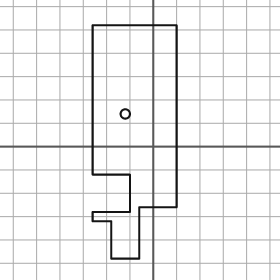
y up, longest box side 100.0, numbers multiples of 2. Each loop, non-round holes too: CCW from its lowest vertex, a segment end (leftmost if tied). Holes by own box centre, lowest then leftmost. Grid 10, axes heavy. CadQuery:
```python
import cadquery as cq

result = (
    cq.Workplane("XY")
    .moveTo(-18.0, -48.0)
    .lineTo(-6.0, -48.0)
    .lineTo(-6.0, -26.0)
    .lineTo(10.0, -26.0)
    .lineTo(10.0, 52.0)
    .lineTo(-26.0, 52.0)
    .lineTo(-26.0, -12.0)
    .lineTo(-10.0, -12.0)
    .lineTo(-10.0, -28.0)
    .lineTo(-26.0, -28.0)
    .lineTo(-26.0, -32.0)
    .lineTo(-18.0, -32.0)
    .close()
    .moveTo(-12.0, 14.0)
    .circle(2.0)
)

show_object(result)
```